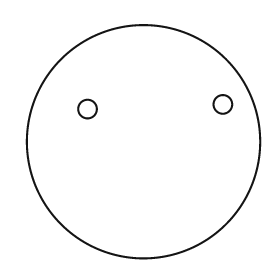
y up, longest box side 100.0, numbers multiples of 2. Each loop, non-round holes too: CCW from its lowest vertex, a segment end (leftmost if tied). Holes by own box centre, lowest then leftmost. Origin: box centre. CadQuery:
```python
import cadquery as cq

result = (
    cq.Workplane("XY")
    .moveTo(0.0, 0.0)
    .circle(50.0)
    .moveTo(-24.0, 14.0)
    .circle(4.0)
    .moveTo(34.0, 16.0)
    .circle(4.0)
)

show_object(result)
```